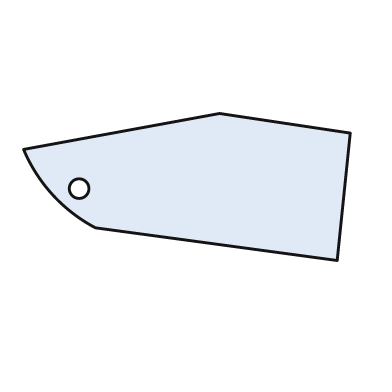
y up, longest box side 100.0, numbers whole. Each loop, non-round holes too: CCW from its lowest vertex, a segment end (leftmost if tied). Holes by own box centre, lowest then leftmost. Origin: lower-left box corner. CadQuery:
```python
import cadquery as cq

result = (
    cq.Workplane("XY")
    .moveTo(96.0, 0.0)
    .lineTo(100.0, 39.0)
    .lineTo(60.0, 45.0)
    .lineTo(0.0, 34.0)
    .threePointArc((9.0, 20.0), (22.0, 10.0))
    .close()
    .moveTo(17.0, 22.0)
    .circle(3.0)
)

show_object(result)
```